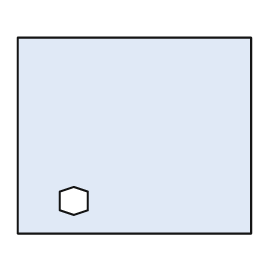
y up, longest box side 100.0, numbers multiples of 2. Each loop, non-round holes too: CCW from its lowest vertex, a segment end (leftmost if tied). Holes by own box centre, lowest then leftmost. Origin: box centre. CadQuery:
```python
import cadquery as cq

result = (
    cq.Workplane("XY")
    .moveTo(-50.0, -42.0)
    .lineTo(50.0, -42.0)
    .lineTo(50.0, 42.0)
    .lineTo(-50.0, 42.0)
    .close()
    .moveTo(-26.0, -34.0)
    .lineTo(-20.0, -32.0)
    .lineTo(-20.0, -24.0)
    .lineTo(-26.0, -22.0)
    .lineTo(-32.0, -24.0)
    .lineTo(-32.0, -32.0)
    .close()
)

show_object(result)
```